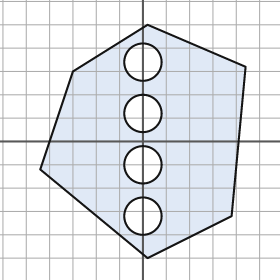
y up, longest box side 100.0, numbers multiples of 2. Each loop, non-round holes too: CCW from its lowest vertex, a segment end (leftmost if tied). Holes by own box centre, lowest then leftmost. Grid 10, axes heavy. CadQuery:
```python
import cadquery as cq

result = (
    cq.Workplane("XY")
    .moveTo(2.0, -50.0)
    .lineTo(38.0, -32.0)
    .lineTo(44.0, 32.0)
    .lineTo(2.0, 50.0)
    .lineTo(-30.0, 30.0)
    .lineTo(-44.0, -12.0)
    .close()
    .moveTo(0.0, -32.0)
    .circle(8.0)
    .moveTo(0.0, -10.0)
    .circle(8.0)
    .moveTo(0.0, 12.0)
    .circle(8.0)
    .moveTo(0.0, 34.0)
    .circle(8.0)
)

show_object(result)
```